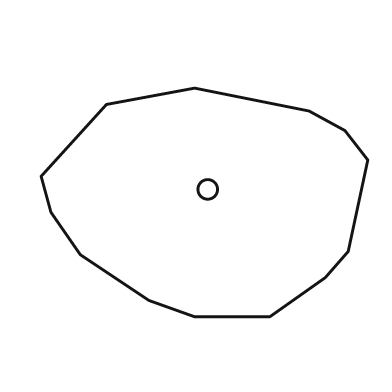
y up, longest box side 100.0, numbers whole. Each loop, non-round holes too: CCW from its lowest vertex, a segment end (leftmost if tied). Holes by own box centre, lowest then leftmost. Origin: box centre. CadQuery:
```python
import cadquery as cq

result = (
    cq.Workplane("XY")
    .moveTo(-3.0, -35.0)
    .lineTo(20.0, -35.0)
    .lineTo(37.0, -23.0)
    .lineTo(44.0, -15.0)
    .lineTo(50.0, 13.0)
    .lineTo(43.0, 22.0)
    .lineTo(32.0, 28.0)
    .lineTo(-3.0, 35.0)
    .lineTo(-30.0, 30.0)
    .lineTo(-50.0, 8.0)
    .lineTo(-47.0, -3.0)
    .lineTo(-38.0, -16.0)
    .lineTo(-17.0, -30.0)
    .close()
    .moveTo(1.0, 4.0)
    .circle(3.0)
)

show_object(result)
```